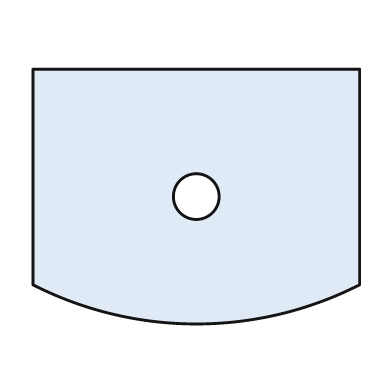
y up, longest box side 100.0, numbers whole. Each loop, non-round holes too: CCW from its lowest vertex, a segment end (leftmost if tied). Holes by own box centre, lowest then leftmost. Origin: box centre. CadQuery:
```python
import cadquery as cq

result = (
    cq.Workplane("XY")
    .moveTo(-50.0, -27.0)
    .threePointArc((0.0, -39.0), (50.0, -27.0))
    .lineTo(50.0, 39.0)
    .lineTo(-50.0, 39.0)
    .close()
    .moveTo(0.0, 0.0)
    .circle(7.0)
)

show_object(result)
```